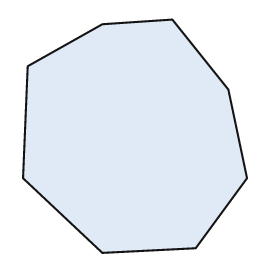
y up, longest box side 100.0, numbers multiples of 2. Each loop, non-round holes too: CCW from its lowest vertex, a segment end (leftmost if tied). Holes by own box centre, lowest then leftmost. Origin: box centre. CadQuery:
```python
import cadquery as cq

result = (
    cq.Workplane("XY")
    .moveTo(-14.0, -50.0)
    .lineTo(26.0, -48.0)
    .lineTo(48.0, -18.0)
    .lineTo(40.0, 20.0)
    .lineTo(16.0, 50.0)
    .lineTo(-14.0, 48.0)
    .lineTo(-46.0, 30.0)
    .lineTo(-48.0, -18.0)
    .close()
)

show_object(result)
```